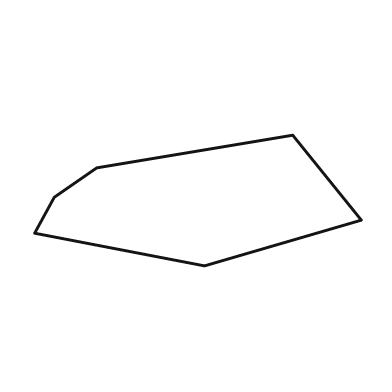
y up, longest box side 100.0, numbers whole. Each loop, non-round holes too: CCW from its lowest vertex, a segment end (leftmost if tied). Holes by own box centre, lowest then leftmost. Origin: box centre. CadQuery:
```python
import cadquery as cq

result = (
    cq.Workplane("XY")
    .moveTo(2.0, -20.0)
    .lineTo(50.0, -6.0)
    .lineTo(29.0, 20.0)
    .lineTo(-31.0, 10.0)
    .lineTo(-44.0, 1.0)
    .lineTo(-50.0, -10.0)
    .close()
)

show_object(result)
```